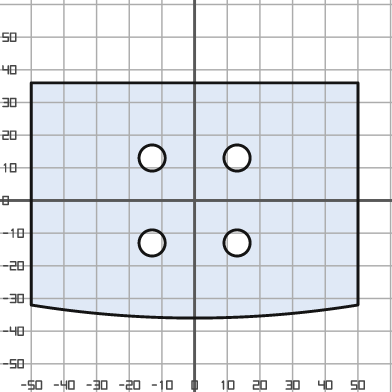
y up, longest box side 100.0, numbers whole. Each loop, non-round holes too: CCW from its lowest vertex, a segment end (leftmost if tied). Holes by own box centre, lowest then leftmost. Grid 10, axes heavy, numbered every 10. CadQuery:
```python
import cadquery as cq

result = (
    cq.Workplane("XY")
    .moveTo(-50.0, -32.0)
    .threePointArc((0.0, -36.0), (50.0, -32.0))
    .lineTo(50.0, 36.0)
    .lineTo(-50.0, 36.0)
    .close()
    .moveTo(-13.0, -13.0)
    .circle(4.0)
    .moveTo(13.0, -13.0)
    .circle(4.0)
    .moveTo(-13.0, 13.0)
    .circle(4.0)
    .moveTo(13.0, 13.0)
    .circle(4.0)
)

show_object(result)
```